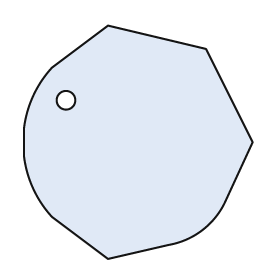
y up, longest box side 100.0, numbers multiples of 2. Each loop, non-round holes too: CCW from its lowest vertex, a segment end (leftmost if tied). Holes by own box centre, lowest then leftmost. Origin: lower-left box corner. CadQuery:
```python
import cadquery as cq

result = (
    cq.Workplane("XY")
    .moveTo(36.0, 0.0)
    .lineTo(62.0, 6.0)
    .threePointArc((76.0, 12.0), (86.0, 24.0))
    .lineTo(98.0, 50.0)
    .lineTo(78.0, 90.0)
    .lineTo(36.0, 100.0)
    .lineTo(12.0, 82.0)
    .threePointArc((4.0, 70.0), (0.0, 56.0))
    .lineTo(0.0, 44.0)
    .threePointArc((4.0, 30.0), (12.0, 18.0))
    .close()
    .moveTo(18.0, 68.0)
    .circle(4.0)
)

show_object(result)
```